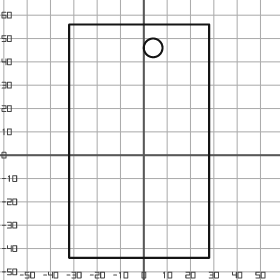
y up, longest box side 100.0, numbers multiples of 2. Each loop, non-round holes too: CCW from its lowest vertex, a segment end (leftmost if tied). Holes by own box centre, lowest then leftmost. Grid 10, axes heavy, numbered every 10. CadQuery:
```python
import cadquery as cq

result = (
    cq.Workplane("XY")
    .moveTo(-32.0, -44.0)
    .lineTo(28.0, -44.0)
    .lineTo(28.0, 56.0)
    .lineTo(-32.0, 56.0)
    .close()
    .moveTo(4.0, 46.0)
    .circle(4.0)
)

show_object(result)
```